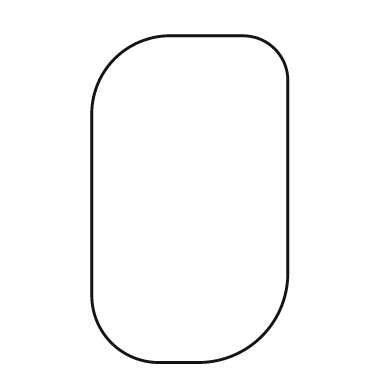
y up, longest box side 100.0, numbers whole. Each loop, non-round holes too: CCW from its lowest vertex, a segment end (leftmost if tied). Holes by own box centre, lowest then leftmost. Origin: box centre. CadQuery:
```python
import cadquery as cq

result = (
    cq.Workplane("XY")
    .moveTo(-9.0, -50.0)
    .lineTo(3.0, -50.0)
    .threePointArc((22.0, -42.0), (30.0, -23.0))
    .lineTo(30.0, 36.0)
    .threePointArc((26.0, 46.0), (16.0, 50.0))
    .lineTo(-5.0, 50.0)
    .threePointArc((-23.0, 43.0), (-30.0, 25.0))
    .lineTo(-30.0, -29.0)
    .threePointArc((-24.0, -44.0), (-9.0, -50.0))
    .close()
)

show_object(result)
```